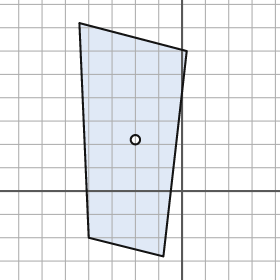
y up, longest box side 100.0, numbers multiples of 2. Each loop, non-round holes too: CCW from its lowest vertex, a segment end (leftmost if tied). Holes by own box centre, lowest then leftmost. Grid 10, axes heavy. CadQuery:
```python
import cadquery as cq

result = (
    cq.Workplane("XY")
    .moveTo(-8.0, -28.0)
    .lineTo(2.0, 60.0)
    .lineTo(-44.0, 72.0)
    .lineTo(-40.0, -20.0)
    .close()
    .moveTo(-20.0, 22.0)
    .circle(2.0)
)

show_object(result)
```